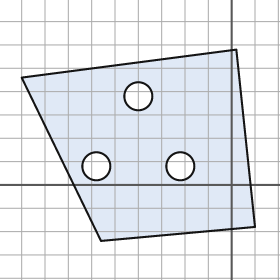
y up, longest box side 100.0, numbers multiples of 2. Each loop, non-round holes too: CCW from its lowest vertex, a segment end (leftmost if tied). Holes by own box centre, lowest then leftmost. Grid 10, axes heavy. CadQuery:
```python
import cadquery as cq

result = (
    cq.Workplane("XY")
    .moveTo(-56.0, -24.0)
    .lineTo(10.0, -18.0)
    .lineTo(2.0, 58.0)
    .lineTo(-90.0, 46.0)
    .close()
    .moveTo(-58.0, 8.0)
    .circle(6.0)
    .moveTo(-22.0, 8.0)
    .circle(6.0)
    .moveTo(-40.0, 38.0)
    .circle(6.0)
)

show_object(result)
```